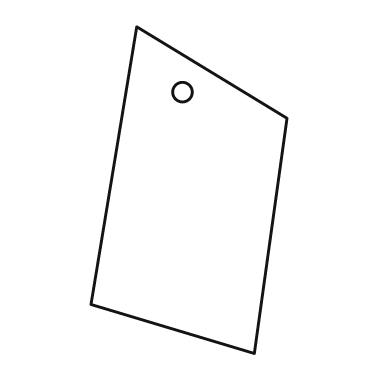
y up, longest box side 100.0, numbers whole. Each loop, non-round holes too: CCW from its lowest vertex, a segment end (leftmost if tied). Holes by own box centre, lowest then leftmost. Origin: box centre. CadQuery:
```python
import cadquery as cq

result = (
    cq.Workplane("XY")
    .moveTo(20.0, -50.0)
    .lineTo(30.0, 22.0)
    .lineTo(-16.0, 50.0)
    .lineTo(-30.0, -35.0)
    .close()
    .moveTo(-2.0, 30.0)
    .circle(3.0)
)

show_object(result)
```